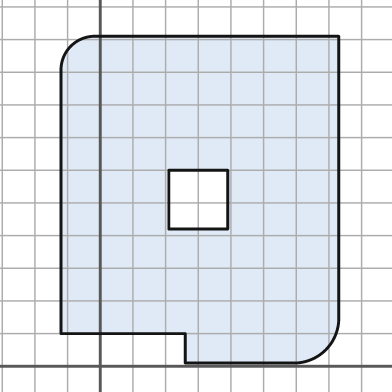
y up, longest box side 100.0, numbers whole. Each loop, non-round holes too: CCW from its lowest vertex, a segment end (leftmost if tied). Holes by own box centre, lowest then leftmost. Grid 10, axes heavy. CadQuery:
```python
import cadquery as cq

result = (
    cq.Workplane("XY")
    .moveTo(26.0, 1.0)
    .lineTo(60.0, 1.0)
    .threePointArc((69.0, 5.0), (73.0, 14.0))
    .lineTo(73.0, 101.0)
    .lineTo(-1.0, 101.0)
    .threePointArc((-9.0, 98.0), (-12.0, 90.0))
    .lineTo(-12.0, 10.0)
    .lineTo(26.0, 10.0)
    .close()
    .moveTo(21.0, 42.0)
    .lineTo(39.0, 42.0)
    .lineTo(39.0, 60.0)
    .lineTo(21.0, 60.0)
    .close()
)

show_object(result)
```